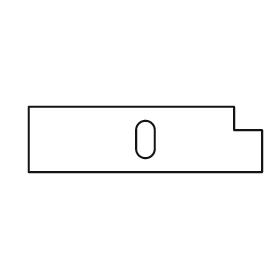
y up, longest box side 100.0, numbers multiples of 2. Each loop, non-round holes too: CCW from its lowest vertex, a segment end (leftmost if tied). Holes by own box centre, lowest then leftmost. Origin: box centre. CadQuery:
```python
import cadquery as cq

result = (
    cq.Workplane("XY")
    .moveTo(-50.0, -14.0)
    .lineTo(50.0, -14.0)
    .lineTo(50.0, 4.0)
    .lineTo(38.0, 4.0)
    .lineTo(38.0, 14.0)
    .lineTo(-50.0, 14.0)
    .close()
    .moveTo(-4.0, -4.0)
    .threePointArc((0.0, -8.0), (4.0, -4.0))
    .lineTo(4.0, 4.0)
    .threePointArc((0.0, 8.0), (-4.0, 4.0))
    .close()
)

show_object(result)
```